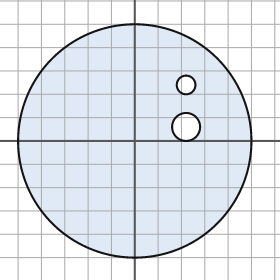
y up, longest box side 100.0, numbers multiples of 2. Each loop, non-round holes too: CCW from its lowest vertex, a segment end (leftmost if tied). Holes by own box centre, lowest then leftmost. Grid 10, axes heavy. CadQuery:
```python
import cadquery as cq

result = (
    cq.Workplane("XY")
    .moveTo(0.0, 0.0)
    .circle(50.0)
    .moveTo(22.0, 6.0)
    .circle(6.0)
    .moveTo(22.0, 24.0)
    .circle(4.0)
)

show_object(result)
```